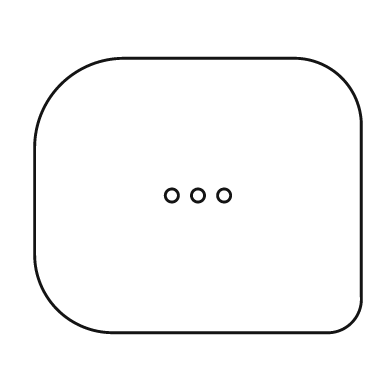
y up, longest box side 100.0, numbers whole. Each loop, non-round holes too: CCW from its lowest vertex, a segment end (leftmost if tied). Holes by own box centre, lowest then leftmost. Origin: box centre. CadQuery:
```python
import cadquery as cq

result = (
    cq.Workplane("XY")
    .moveTo(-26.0, -42.0)
    .lineTo(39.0, -42.0)
    .threePointArc((47.0, -39.0), (50.0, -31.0))
    .lineTo(50.0, 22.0)
    .threePointArc((44.0, 36.0), (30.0, 42.0))
    .lineTo(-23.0, 42.0)
    .threePointArc((-42.0, 34.0), (-50.0, 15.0))
    .lineTo(-50.0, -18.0)
    .threePointArc((-43.0, -35.0), (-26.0, -42.0))
    .close()
    .moveTo(-8.0, 0.0)
    .circle(2.0)
    .moveTo(0.0, 0.0)
    .circle(2.0)
    .moveTo(8.0, 0.0)
    .circle(2.0)
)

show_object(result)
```